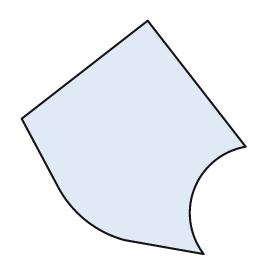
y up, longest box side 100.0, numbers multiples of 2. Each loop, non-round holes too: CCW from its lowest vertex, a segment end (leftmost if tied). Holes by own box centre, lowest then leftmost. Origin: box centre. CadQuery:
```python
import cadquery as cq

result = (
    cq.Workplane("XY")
    .moveTo(30.0, -50.0)
    .threePointArc((26.0, -22.0), (48.0, -4.0))
    .lineTo(6.0, 50.0)
    .lineTo(-48.0, 8.0)
    .lineTo(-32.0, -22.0)
    .threePointArc((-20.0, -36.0), (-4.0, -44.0))
    .close()
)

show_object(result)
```